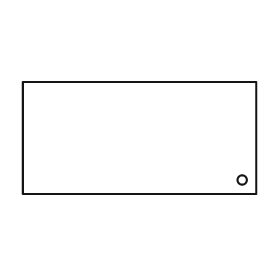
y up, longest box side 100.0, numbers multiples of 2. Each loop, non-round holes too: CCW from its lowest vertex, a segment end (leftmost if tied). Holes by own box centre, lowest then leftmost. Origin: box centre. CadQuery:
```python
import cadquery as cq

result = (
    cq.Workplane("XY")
    .moveTo(-50.0, -24.0)
    .lineTo(50.0, -24.0)
    .lineTo(50.0, 24.0)
    .lineTo(-50.0, 24.0)
    .close()
    .moveTo(44.0, -18.0)
    .circle(2.0)
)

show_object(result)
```